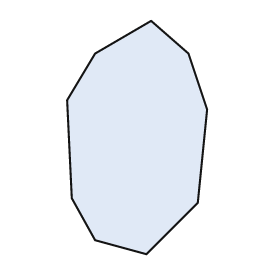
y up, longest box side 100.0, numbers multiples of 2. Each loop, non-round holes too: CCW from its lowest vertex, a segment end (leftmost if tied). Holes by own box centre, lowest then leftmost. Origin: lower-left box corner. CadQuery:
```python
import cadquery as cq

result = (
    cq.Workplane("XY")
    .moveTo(34.0, 0.0)
    .lineTo(56.0, 22.0)
    .lineTo(60.0, 62.0)
    .lineTo(52.0, 86.0)
    .lineTo(36.0, 100.0)
    .lineTo(12.0, 86.0)
    .lineTo(0.0, 66.0)
    .lineTo(2.0, 24.0)
    .lineTo(12.0, 6.0)
    .close()
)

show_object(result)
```